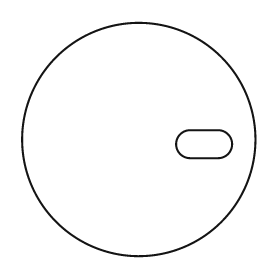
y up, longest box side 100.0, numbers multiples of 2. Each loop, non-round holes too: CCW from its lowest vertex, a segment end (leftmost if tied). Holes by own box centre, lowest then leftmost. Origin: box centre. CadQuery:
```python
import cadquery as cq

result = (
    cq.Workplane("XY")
    .moveTo(0.0, 0.0)
    .circle(50.0)
    .moveTo(22.0, -8.0)
    .lineTo(34.0, -8.0)
    .threePointArc((40.0, -2.0), (34.0, 4.0))
    .lineTo(22.0, 4.0)
    .threePointArc((16.0, -2.0), (22.0, -8.0))
    .close()
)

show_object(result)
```